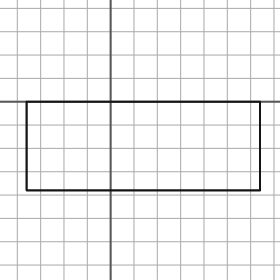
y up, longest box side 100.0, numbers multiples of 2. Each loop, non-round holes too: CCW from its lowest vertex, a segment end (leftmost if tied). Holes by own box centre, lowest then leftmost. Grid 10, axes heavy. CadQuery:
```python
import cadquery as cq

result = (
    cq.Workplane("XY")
    .moveTo(-36.0, -38.0)
    .lineTo(64.0, -38.0)
    .lineTo(64.0, 0.0)
    .lineTo(-36.0, 0.0)
    .close()
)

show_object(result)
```